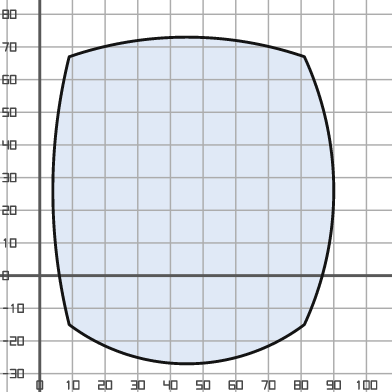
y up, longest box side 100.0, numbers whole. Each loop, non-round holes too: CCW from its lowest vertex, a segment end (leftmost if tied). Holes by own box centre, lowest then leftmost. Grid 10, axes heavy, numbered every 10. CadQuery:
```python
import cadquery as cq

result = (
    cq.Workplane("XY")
    .moveTo(9.0, -15.0)
    .threePointArc((45.0, -27.0), (81.0, -15.0))
    .threePointArc((90.0, 26.0), (81.0, 67.0))
    .threePointArc((45.0, 73.0), (9.0, 67.0))
    .threePointArc((4.0, 26.0), (9.0, -15.0))
    .close()
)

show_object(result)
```